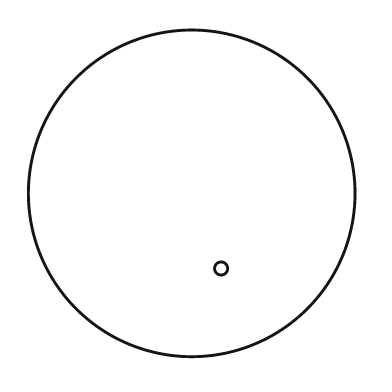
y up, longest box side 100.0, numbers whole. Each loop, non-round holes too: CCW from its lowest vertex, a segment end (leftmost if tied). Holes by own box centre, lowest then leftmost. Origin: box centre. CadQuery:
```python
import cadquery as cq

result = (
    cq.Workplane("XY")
    .moveTo(0.0, 0.0)
    .circle(50.0)
    .moveTo(9.0, -23.0)
    .circle(2.0)
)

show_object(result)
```